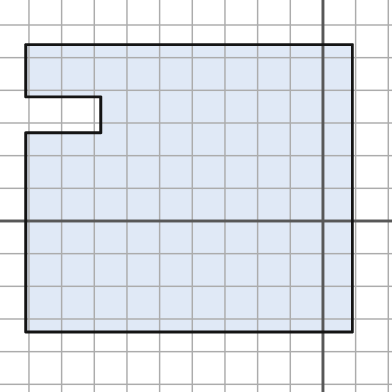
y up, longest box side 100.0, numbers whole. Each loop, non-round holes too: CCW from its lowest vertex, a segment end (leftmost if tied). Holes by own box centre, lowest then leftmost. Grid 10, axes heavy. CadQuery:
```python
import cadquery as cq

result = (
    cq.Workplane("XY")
    .moveTo(-91.0, -34.0)
    .lineTo(9.0, -34.0)
    .lineTo(9.0, 54.0)
    .lineTo(-91.0, 54.0)
    .lineTo(-91.0, 38.0)
    .lineTo(-68.0, 38.0)
    .lineTo(-68.0, 27.0)
    .lineTo(-91.0, 27.0)
    .close()
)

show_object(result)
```